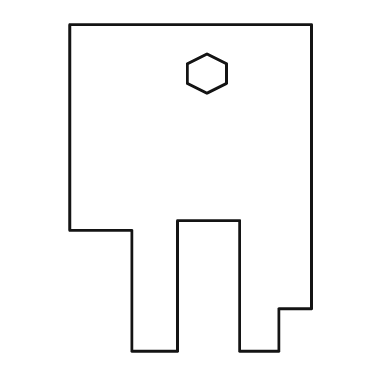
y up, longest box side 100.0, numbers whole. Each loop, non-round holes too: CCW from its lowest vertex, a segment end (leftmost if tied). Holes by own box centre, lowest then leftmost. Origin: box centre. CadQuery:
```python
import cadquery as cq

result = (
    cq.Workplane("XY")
    .moveTo(-18.0, -50.0)
    .lineTo(-4.0, -50.0)
    .lineTo(-4.0, -10.0)
    .lineTo(15.0, -10.0)
    .lineTo(15.0, -50.0)
    .lineTo(27.0, -50.0)
    .lineTo(27.0, -37.0)
    .lineTo(37.0, -37.0)
    .lineTo(37.0, 50.0)
    .lineTo(-37.0, 50.0)
    .lineTo(-37.0, -13.0)
    .lineTo(-18.0, -13.0)
    .close()
    .moveTo(5.0, 29.0)
    .lineTo(11.0, 32.0)
    .lineTo(11.0, 38.0)
    .lineTo(5.0, 41.0)
    .lineTo(-1.0, 38.0)
    .lineTo(-1.0, 32.0)
    .close()
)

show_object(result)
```